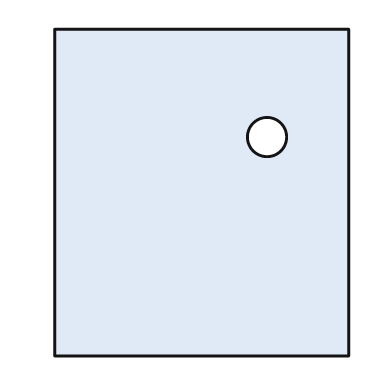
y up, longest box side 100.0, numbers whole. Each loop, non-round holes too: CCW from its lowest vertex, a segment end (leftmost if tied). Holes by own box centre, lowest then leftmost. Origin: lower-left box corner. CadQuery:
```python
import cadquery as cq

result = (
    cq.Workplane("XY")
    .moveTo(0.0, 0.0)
    .lineTo(90.0, 0.0)
    .lineTo(90.0, 100.0)
    .lineTo(0.0, 100.0)
    .close()
    .moveTo(65.0, 67.0)
    .circle(6.0)
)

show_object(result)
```